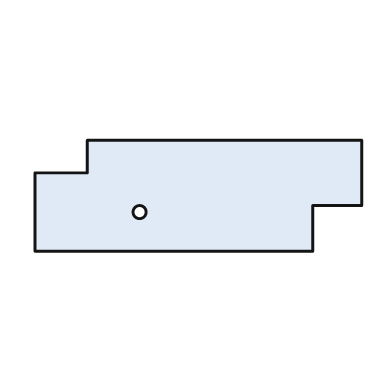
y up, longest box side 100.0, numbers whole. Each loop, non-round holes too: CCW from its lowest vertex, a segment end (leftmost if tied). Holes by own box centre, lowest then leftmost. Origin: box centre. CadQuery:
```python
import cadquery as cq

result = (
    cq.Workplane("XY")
    .moveTo(-50.0, -17.0)
    .lineTo(35.0, -17.0)
    .lineTo(35.0, -3.0)
    .lineTo(50.0, -3.0)
    .lineTo(50.0, 17.0)
    .lineTo(-34.0, 17.0)
    .lineTo(-34.0, 7.0)
    .lineTo(-50.0, 7.0)
    .close()
    .moveTo(-18.0, -5.0)
    .circle(2.0)
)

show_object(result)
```